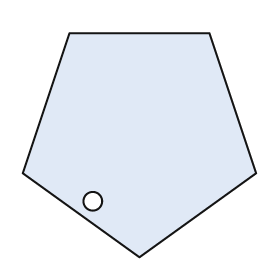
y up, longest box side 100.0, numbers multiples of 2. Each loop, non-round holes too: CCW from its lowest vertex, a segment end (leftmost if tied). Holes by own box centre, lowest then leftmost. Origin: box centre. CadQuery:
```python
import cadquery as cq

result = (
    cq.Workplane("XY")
    .moveTo(0.0, -48.0)
    .lineTo(50.0, -12.0)
    .lineTo(30.0, 48.0)
    .lineTo(-30.0, 48.0)
    .lineTo(-50.0, -12.0)
    .close()
    .moveTo(-20.0, -24.0)
    .circle(4.0)
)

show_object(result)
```